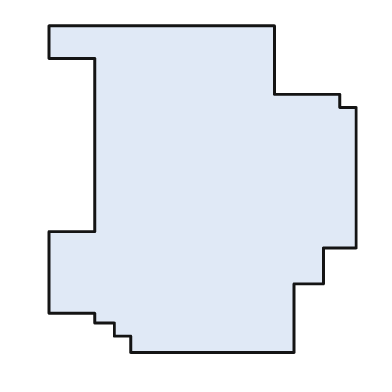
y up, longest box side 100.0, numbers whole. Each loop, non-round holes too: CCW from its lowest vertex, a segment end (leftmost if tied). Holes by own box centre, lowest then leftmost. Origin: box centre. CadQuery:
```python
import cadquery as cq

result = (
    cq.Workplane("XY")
    .moveTo(-22.0, -50.0)
    .lineTo(28.0, -50.0)
    .lineTo(28.0, -29.0)
    .lineTo(37.0, -29.0)
    .lineTo(37.0, -18.0)
    .lineTo(47.0, -18.0)
    .lineTo(47.0, 25.0)
    .lineTo(42.0, 25.0)
    .lineTo(42.0, 29.0)
    .lineTo(22.0, 29.0)
    .lineTo(22.0, 50.0)
    .lineTo(-47.0, 50.0)
    .lineTo(-47.0, 40.0)
    .lineTo(-33.0, 40.0)
    .lineTo(-33.0, -13.0)
    .lineTo(-47.0, -13.0)
    .lineTo(-47.0, -38.0)
    .lineTo(-33.0, -38.0)
    .lineTo(-33.0, -41.0)
    .lineTo(-27.0, -41.0)
    .lineTo(-27.0, -45.0)
    .lineTo(-22.0, -45.0)
    .close()
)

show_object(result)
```